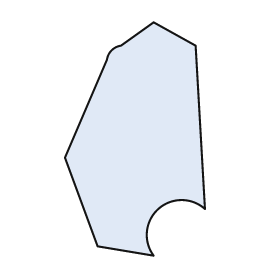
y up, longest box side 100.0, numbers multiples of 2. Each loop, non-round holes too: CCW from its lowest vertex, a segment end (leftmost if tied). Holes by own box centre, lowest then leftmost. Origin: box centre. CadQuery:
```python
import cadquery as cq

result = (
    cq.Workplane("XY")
    .moveTo(8.0, -50.0)
    .threePointArc((10.0, -30.0), (30.0, -30.0))
    .lineTo(26.0, 40.0)
    .lineTo(8.0, 50.0)
    .lineTo(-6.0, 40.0)
    .threePointArc((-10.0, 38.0), (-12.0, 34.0))
    .lineTo(-30.0, -8.0)
    .lineTo(-16.0, -46.0)
    .close()
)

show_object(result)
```